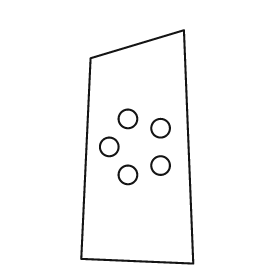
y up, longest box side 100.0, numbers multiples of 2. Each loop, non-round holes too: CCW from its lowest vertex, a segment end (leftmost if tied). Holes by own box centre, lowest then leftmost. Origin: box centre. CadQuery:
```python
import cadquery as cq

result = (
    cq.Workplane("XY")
    .moveTo(24.0, -50.0)
    .lineTo(20.0, 50.0)
    .lineTo(-20.0, 38.0)
    .lineTo(-24.0, -48.0)
    .close()
    .moveTo(-4.0, -12.0)
    .circle(4.0)
    .moveTo(10.0, -8.0)
    .circle(4.0)
    .moveTo(-12.0, 0.0)
    .circle(4.0)
    .moveTo(10.0, 8.0)
    .circle(4.0)
    .moveTo(-4.0, 12.0)
    .circle(4.0)
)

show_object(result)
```